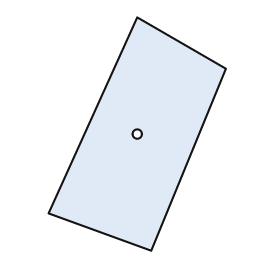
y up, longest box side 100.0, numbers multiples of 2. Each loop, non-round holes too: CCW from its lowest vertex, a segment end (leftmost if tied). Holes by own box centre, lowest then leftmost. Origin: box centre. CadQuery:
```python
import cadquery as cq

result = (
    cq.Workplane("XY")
    .moveTo(6.0, -50.0)
    .lineTo(38.0, 28.0)
    .lineTo(0.0, 50.0)
    .lineTo(-38.0, -34.0)
    .close()
    .moveTo(0.0, 0.0)
    .circle(2.0)
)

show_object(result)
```